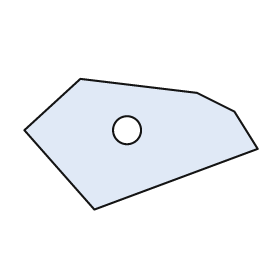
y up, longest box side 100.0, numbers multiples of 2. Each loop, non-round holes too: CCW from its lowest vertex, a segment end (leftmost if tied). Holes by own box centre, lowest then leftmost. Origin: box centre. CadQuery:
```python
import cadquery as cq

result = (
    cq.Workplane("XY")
    .moveTo(-20.0, -28.0)
    .lineTo(50.0, -2.0)
    .lineTo(40.0, 14.0)
    .lineTo(24.0, 22.0)
    .lineTo(-26.0, 28.0)
    .lineTo(-50.0, 6.0)
    .close()
    .moveTo(-6.0, 6.0)
    .circle(6.0)
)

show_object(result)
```